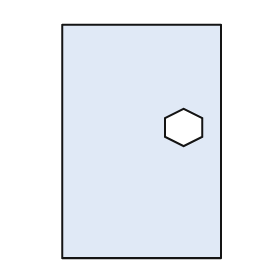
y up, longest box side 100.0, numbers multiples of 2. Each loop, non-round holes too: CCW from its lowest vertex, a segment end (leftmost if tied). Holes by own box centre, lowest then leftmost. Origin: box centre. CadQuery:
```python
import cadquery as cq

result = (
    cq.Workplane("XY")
    .moveTo(-34.0, -50.0)
    .lineTo(34.0, -50.0)
    .lineTo(34.0, 50.0)
    .lineTo(-34.0, 50.0)
    .close()
    .moveTo(18.0, -2.0)
    .lineTo(26.0, 2.0)
    .lineTo(26.0, 10.0)
    .lineTo(18.0, 14.0)
    .lineTo(10.0, 10.0)
    .lineTo(10.0, 2.0)
    .close()
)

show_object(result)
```